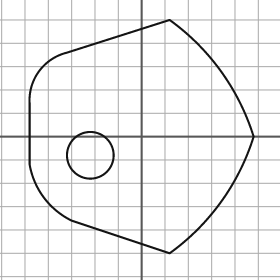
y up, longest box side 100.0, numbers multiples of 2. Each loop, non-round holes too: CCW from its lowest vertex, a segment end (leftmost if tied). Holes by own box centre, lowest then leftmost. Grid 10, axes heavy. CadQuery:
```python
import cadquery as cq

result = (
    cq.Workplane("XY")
    .moveTo(12.0, -50.0)
    .threePointArc((34.0, -28.0), (48.0, 0.0))
    .threePointArc((34.0, 28.0), (12.0, 50.0))
    .lineTo(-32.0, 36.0)
    .threePointArc((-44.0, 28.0), (-48.0, 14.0))
    .lineTo(-48.0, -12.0)
    .threePointArc((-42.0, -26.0), (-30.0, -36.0))
    .close()
    .moveTo(-22.0, -8.0)
    .circle(10.0)
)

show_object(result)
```